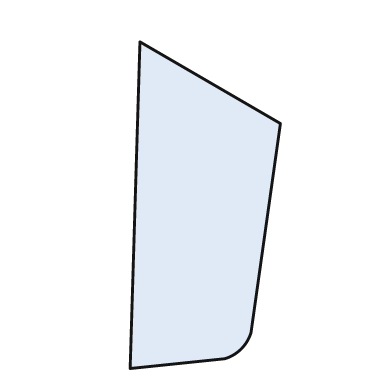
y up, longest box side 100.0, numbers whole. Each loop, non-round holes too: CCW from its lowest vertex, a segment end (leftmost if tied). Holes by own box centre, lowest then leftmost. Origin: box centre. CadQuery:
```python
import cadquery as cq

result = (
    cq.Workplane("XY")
    .moveTo(-23.0, -50.0)
    .lineTo(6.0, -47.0)
    .threePointArc((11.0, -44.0), (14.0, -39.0))
    .lineTo(23.0, 25.0)
    .lineTo(-20.0, 50.0)
    .close()
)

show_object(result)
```